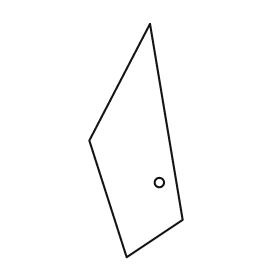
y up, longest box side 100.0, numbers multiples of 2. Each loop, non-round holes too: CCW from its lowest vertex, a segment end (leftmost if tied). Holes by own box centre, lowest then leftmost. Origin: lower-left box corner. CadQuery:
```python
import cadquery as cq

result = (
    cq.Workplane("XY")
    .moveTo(16.0, 0.0)
    .lineTo(40.0, 16.0)
    .lineTo(26.0, 100.0)
    .lineTo(0.0, 50.0)
    .close()
    .moveTo(30.0, 32.0)
    .circle(2.0)
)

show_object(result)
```